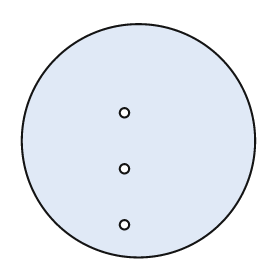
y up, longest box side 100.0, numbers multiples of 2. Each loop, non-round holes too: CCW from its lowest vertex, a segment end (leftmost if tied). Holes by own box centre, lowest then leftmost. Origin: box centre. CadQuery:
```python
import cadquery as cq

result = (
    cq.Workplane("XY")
    .moveTo(0.0, 0.0)
    .circle(50.0)
    .moveTo(-6.0, -36.0)
    .circle(2.0)
    .moveTo(-6.0, -12.0)
    .circle(2.0)
    .moveTo(-6.0, 12.0)
    .circle(2.0)
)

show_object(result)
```